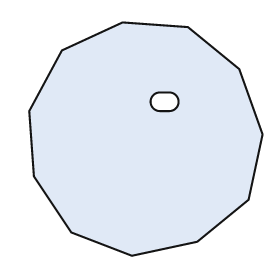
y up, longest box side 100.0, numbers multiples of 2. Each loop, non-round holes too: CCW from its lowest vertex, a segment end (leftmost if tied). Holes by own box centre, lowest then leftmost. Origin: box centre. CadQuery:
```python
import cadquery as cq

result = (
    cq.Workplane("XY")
    .moveTo(-6.0, -50.0)
    .lineTo(22.0, -44.0)
    .lineTo(44.0, -26.0)
    .lineTo(50.0, 2.0)
    .lineTo(40.0, 30.0)
    .lineTo(18.0, 48.0)
    .lineTo(-10.0, 50.0)
    .lineTo(-36.0, 38.0)
    .lineTo(-50.0, 12.0)
    .lineTo(-48.0, -16.0)
    .lineTo(-32.0, -40.0)
    .close()
    .moveTo(6.0, 12.0)
    .lineTo(10.0, 12.0)
    .threePointArc((14.0, 16.0), (10.0, 20.0))
    .lineTo(6.0, 20.0)
    .threePointArc((2.0, 16.0), (6.0, 12.0))
    .close()
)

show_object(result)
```